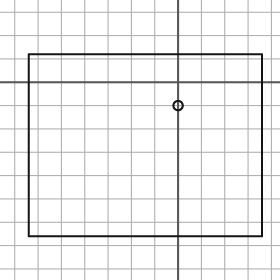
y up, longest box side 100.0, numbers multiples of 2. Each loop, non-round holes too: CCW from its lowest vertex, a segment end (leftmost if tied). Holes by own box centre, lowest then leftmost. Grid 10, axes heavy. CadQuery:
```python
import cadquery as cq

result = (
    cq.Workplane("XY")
    .moveTo(-64.0, -66.0)
    .lineTo(36.0, -66.0)
    .lineTo(36.0, 12.0)
    .lineTo(-64.0, 12.0)
    .close()
    .moveTo(0.0, -10.0)
    .circle(2.0)
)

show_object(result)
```